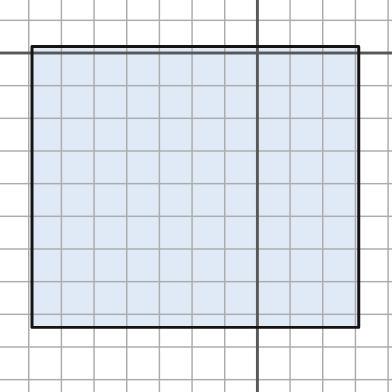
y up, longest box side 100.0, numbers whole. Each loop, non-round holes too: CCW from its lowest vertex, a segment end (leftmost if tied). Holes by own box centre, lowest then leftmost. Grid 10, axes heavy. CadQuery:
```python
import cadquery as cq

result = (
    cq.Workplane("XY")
    .moveTo(-69.0, -84.0)
    .lineTo(31.0, -84.0)
    .lineTo(31.0, 2.0)
    .lineTo(-69.0, 2.0)
    .close()
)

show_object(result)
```